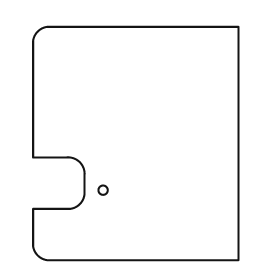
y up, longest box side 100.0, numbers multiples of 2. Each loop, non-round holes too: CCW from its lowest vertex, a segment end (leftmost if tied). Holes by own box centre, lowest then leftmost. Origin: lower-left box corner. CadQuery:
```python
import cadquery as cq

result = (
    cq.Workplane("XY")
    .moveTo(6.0, 0.0)
    .lineTo(88.0, 0.0)
    .lineTo(88.0, 100.0)
    .lineTo(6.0, 100.0)
    .threePointArc((2.0, 98.0), (0.0, 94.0))
    .lineTo(0.0, 44.0)
    .lineTo(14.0, 44.0)
    .threePointArc((20.0, 42.0), (22.0, 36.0))
    .lineTo(22.0, 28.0)
    .threePointArc((20.0, 24.0), (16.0, 22.0))
    .lineTo(0.0, 22.0)
    .lineTo(0.0, 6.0)
    .threePointArc((2.0, 2.0), (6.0, 0.0))
    .close()
    .moveTo(30.0, 30.0)
    .circle(2.0)
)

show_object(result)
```